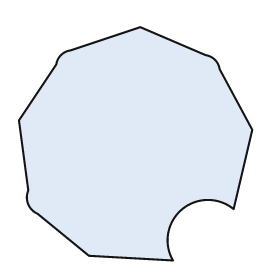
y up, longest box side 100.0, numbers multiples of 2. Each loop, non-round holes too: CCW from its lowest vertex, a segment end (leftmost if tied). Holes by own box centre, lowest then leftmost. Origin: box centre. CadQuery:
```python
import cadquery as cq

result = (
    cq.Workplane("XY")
    .moveTo(16.0, -50.0)
    .threePointArc((20.0, -28.0), (42.0, -28.0))
    .lineTo(50.0, 6.0)
    .lineTo(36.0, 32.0)
    .threePointArc((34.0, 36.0), (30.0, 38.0))
    .lineTo(2.0, 50.0)
    .lineTo(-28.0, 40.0)
    .threePointArc((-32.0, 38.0), (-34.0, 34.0))
    .lineTo(-50.0, 10.0)
    .lineTo(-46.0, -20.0)
    .threePointArc((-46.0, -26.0), (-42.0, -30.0))
    .lineTo(-20.0, -48.0)
    .close()
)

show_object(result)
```